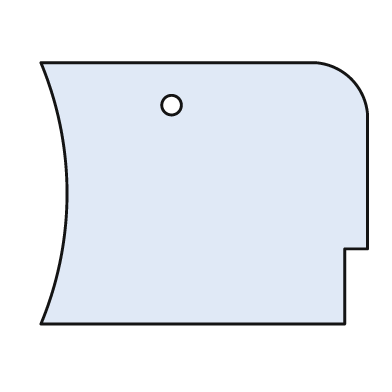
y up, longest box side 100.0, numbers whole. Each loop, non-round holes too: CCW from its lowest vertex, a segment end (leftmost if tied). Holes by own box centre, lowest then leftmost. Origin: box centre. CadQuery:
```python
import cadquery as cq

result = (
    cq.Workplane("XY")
    .moveTo(-50.0, -40.0)
    .lineTo(43.0, -40.0)
    .lineTo(43.0, -17.0)
    .lineTo(50.0, -17.0)
    .lineTo(50.0, 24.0)
    .threePointArc((45.0, 35.0), (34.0, 40.0))
    .lineTo(-50.0, 40.0)
    .threePointArc((-42.0, 0.0), (-50.0, -40.0))
    .close()
    .moveTo(-10.0, 27.0)
    .circle(3.0)
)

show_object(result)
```